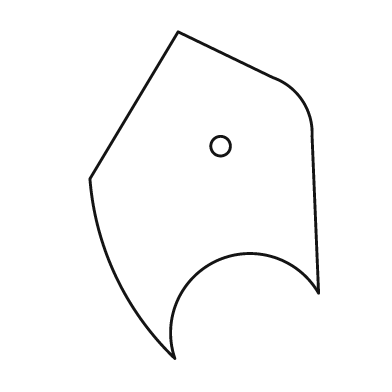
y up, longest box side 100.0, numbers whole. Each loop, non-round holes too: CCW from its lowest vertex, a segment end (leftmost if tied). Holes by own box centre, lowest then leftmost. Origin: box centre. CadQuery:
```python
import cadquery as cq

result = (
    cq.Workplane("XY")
    .moveTo(-9.0, -50.0)
    .threePointArc((4.0, -20.0), (35.0, -30.0))
    .lineTo(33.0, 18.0)
    .threePointArc((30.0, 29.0), (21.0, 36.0))
    .lineTo(-8.0, 50.0)
    .lineTo(-35.0, 5.0)
    .threePointArc((-27.0, -25.0), (-9.0, -50.0))
    .close()
    .moveTo(5.0, 15.0)
    .circle(3.0)
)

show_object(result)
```